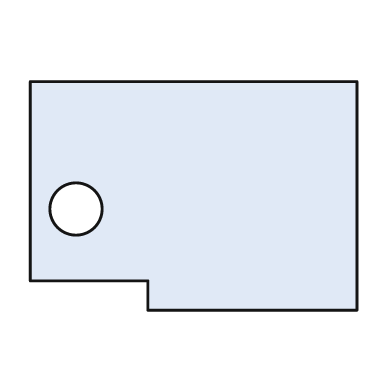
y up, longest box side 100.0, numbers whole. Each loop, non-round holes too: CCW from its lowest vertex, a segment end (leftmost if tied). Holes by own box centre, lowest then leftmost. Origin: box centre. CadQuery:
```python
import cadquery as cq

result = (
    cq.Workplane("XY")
    .moveTo(-14.0, -35.0)
    .lineTo(50.0, -35.0)
    .lineTo(50.0, 35.0)
    .lineTo(-50.0, 35.0)
    .lineTo(-50.0, -26.0)
    .lineTo(-14.0, -26.0)
    .close()
    .moveTo(-36.0, -4.0)
    .circle(8.0)
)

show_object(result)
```